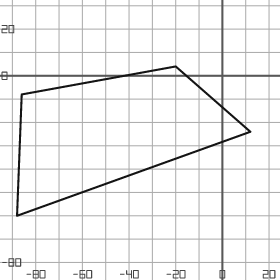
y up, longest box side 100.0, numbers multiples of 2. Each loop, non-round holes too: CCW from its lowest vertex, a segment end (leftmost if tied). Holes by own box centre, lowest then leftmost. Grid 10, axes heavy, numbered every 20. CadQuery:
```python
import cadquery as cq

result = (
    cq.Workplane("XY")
    .moveTo(-88.0, -60.0)
    .lineTo(12.0, -24.0)
    .lineTo(-20.0, 4.0)
    .lineTo(-86.0, -8.0)
    .close()
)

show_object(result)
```